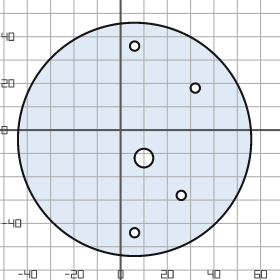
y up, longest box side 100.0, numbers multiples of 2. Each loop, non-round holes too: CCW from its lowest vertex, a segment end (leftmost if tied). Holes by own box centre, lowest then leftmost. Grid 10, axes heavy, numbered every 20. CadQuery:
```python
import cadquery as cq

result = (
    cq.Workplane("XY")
    .moveTo(6.0, -4.0)
    .circle(50.0)
    .moveTo(6.0, -44.0)
    .circle(2.0)
    .moveTo(26.0, -28.0)
    .circle(2.0)
    .moveTo(10.0, -12.0)
    .circle(4.0)
    .moveTo(32.0, 18.0)
    .circle(2.0)
    .moveTo(6.0, 36.0)
    .circle(2.0)
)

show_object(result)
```